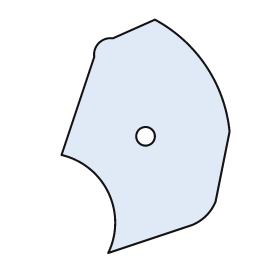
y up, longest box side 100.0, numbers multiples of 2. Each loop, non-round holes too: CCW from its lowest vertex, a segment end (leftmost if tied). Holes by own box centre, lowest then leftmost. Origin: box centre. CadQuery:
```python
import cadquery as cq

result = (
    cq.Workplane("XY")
    .moveTo(-16.0, -50.0)
    .lineTo(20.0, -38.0)
    .threePointArc((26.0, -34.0), (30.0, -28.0))
    .lineTo(36.0, 2.0)
    .threePointArc((26.0, 30.0), (4.0, 50.0))
    .lineTo(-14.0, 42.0)
    .threePointArc((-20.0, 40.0), (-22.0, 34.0))
    .lineTo(-36.0, -8.0)
    .threePointArc((-16.0, -24.0), (-16.0, -50.0))
    .close()
    .moveTo(0.0, 0.0)
    .circle(4.0)
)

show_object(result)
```